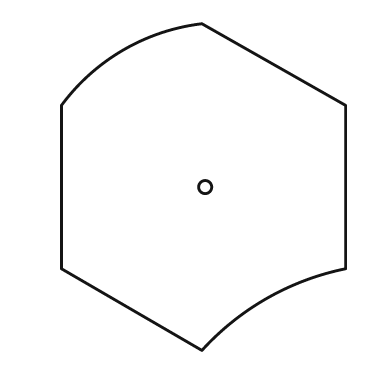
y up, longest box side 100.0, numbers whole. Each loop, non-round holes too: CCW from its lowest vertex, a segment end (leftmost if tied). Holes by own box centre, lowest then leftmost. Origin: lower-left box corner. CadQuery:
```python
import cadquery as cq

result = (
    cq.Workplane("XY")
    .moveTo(43.0, 0.0)
    .threePointArc((63.0, 16.0), (87.0, 25.0))
    .lineTo(87.0, 75.0)
    .lineTo(43.0, 100.0)
    .threePointArc((19.0, 92.0), (0.0, 75.0))
    .lineTo(0.0, 25.0)
    .close()
    .moveTo(44.0, 50.0)
    .circle(2.0)
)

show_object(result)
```